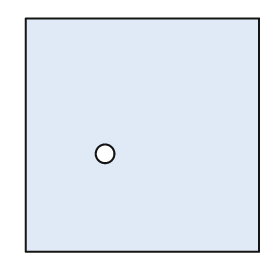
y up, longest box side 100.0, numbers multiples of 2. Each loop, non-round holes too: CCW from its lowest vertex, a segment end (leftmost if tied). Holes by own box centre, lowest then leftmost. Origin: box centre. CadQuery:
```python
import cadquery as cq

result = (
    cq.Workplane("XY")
    .moveTo(-50.0, -50.0)
    .lineTo(50.0, -50.0)
    .lineTo(50.0, 50.0)
    .lineTo(-50.0, 50.0)
    .close()
    .moveTo(-16.0, -8.0)
    .circle(4.0)
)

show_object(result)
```